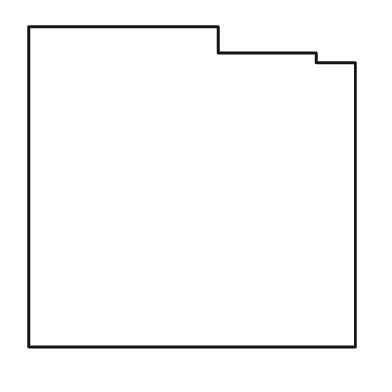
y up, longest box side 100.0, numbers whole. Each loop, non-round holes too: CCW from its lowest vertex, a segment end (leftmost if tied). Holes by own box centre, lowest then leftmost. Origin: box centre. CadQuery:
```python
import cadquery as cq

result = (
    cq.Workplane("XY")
    .moveTo(-50.0, -49.0)
    .lineTo(50.0, -49.0)
    .lineTo(50.0, 38.0)
    .lineTo(38.0, 38.0)
    .lineTo(38.0, 41.0)
    .lineTo(8.0, 41.0)
    .lineTo(8.0, 49.0)
    .lineTo(-50.0, 49.0)
    .close()
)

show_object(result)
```